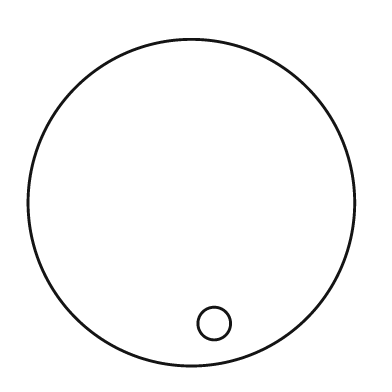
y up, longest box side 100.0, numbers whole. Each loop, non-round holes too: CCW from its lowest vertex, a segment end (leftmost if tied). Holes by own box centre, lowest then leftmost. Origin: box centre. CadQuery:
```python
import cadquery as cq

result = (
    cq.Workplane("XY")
    .moveTo(0.0, 0.0)
    .circle(50.0)
    .moveTo(7.0, -37.0)
    .circle(5.0)
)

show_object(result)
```